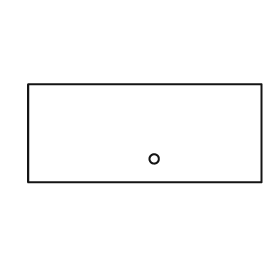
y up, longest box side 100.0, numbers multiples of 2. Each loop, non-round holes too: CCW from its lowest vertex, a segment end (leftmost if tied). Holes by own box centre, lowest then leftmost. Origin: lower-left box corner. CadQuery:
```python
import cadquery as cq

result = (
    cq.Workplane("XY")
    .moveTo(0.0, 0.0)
    .lineTo(100.0, 0.0)
    .lineTo(100.0, 42.0)
    .lineTo(0.0, 42.0)
    .close()
    .moveTo(54.0, 10.0)
    .circle(2.0)
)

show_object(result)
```